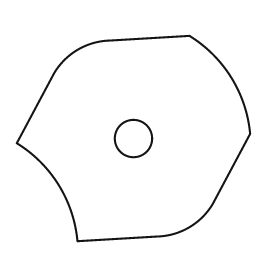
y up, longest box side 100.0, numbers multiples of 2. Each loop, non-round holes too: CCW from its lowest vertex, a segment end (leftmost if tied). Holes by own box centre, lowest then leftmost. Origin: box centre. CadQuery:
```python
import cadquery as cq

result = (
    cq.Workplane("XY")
    .moveTo(-24.0, -44.0)
    .lineTo(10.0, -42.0)
    .threePointArc((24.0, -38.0), (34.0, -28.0))
    .lineTo(50.0, 2.0)
    .threePointArc((42.0, 26.0), (24.0, 44.0))
    .lineTo(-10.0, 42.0)
    .threePointArc((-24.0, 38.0), (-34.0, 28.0))
    .lineTo(-50.0, -2.0)
    .threePointArc((-32.0, -20.0), (-24.0, -44.0))
    .close()
    .moveTo(0.0, 0.0)
    .circle(8.0)
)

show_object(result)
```